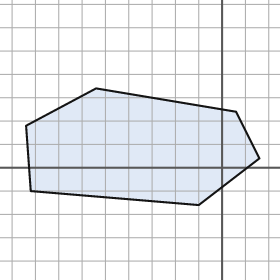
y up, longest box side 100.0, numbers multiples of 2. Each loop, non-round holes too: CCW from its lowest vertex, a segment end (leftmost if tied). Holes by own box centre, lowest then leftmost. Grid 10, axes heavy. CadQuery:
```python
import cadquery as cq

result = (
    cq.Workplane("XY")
    .moveTo(-10.0, -16.0)
    .lineTo(16.0, 4.0)
    .lineTo(6.0, 24.0)
    .lineTo(-54.0, 34.0)
    .lineTo(-84.0, 18.0)
    .lineTo(-82.0, -10.0)
    .close()
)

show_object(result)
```